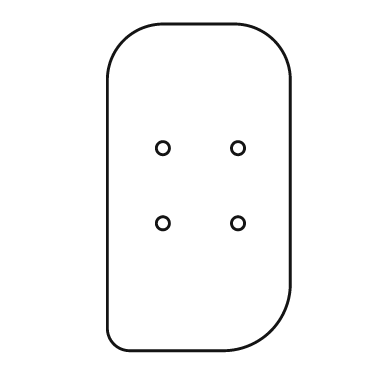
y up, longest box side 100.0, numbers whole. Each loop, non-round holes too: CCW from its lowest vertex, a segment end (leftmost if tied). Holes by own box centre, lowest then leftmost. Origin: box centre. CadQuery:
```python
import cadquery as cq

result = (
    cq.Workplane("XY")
    .moveTo(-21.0, -50.0)
    .lineTo(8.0, -50.0)
    .threePointArc((22.0, -44.0), (28.0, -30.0))
    .lineTo(28.0, 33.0)
    .threePointArc((23.0, 45.0), (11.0, 50.0))
    .lineTo(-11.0, 50.0)
    .threePointArc((-23.0, 45.0), (-28.0, 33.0))
    .lineTo(-28.0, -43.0)
    .threePointArc((-26.0, -48.0), (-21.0, -50.0))
    .close()
    .moveTo(-11.0, -11.0)
    .circle(2.0)
    .moveTo(12.0, -11.0)
    .circle(2.0)
    .moveTo(-11.0, 12.0)
    .circle(2.0)
    .moveTo(12.0, 12.0)
    .circle(2.0)
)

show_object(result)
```